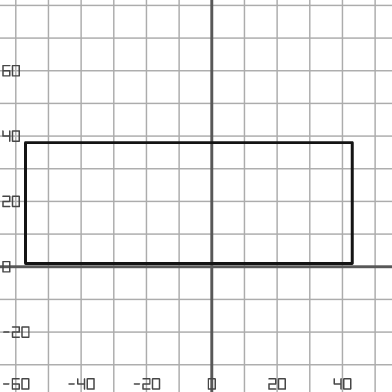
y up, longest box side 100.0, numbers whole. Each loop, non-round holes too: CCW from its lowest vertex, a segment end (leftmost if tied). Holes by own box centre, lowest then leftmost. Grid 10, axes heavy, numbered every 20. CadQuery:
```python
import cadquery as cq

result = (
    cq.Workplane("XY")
    .moveTo(-57.0, 1.0)
    .lineTo(43.0, 1.0)
    .lineTo(43.0, 38.0)
    .lineTo(-57.0, 38.0)
    .close()
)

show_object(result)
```